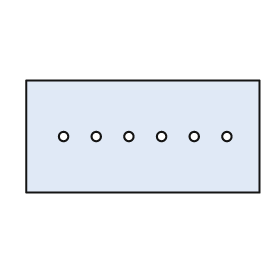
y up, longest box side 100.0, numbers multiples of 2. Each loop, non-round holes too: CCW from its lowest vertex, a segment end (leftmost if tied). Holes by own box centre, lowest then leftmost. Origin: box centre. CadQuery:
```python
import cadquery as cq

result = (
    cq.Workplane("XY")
    .moveTo(-50.0, -24.0)
    .lineTo(50.0, -24.0)
    .lineTo(50.0, 24.0)
    .lineTo(-50.0, 24.0)
    .close()
    .moveTo(-34.0, 0.0)
    .circle(2.0)
    .moveTo(-20.0, 0.0)
    .circle(2.0)
    .moveTo(-6.0, 0.0)
    .circle(2.0)
    .moveTo(8.0, 0.0)
    .circle(2.0)
    .moveTo(22.0, 0.0)
    .circle(2.0)
    .moveTo(36.0, 0.0)
    .circle(2.0)
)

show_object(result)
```